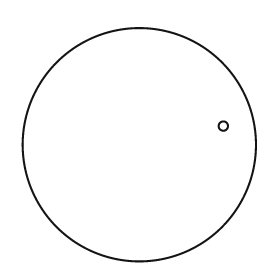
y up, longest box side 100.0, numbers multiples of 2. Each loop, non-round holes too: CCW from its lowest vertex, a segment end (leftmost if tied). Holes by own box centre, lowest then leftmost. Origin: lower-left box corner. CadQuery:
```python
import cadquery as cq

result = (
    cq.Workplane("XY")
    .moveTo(50.0, 50.0)
    .circle(50.0)
    .moveTo(86.0, 58.0)
    .circle(2.0)
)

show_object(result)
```